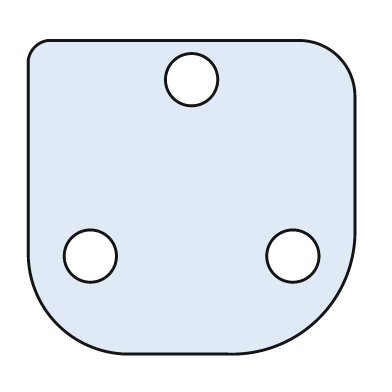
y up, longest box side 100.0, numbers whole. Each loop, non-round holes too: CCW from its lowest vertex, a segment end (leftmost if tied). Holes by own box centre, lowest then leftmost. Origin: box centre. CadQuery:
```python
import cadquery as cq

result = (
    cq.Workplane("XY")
    .moveTo(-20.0, -48.0)
    .lineTo(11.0, -48.0)
    .threePointArc((39.0, -37.0), (50.0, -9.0))
    .lineTo(50.0, 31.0)
    .threePointArc((45.0, 43.0), (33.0, 48.0))
    .lineTo(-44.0, 48.0)
    .threePointArc((-48.0, 46.0), (-50.0, 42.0))
    .lineTo(-50.0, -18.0)
    .threePointArc((-41.0, -39.0), (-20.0, -48.0))
    .close()
    .moveTo(-31.0, -18.0)
    .circle(8.0)
    .moveTo(31.0, -18.0)
    .circle(8.0)
    .moveTo(0.0, 36.0)
    .circle(8.0)
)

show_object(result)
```